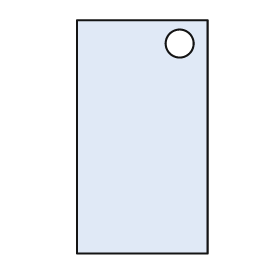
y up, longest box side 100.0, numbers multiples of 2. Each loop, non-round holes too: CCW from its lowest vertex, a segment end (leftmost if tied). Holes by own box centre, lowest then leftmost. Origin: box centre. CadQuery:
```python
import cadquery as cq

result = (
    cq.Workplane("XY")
    .moveTo(-28.0, -50.0)
    .lineTo(28.0, -50.0)
    .lineTo(28.0, 50.0)
    .lineTo(-28.0, 50.0)
    .close()
    .moveTo(16.0, 40.0)
    .circle(6.0)
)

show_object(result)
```